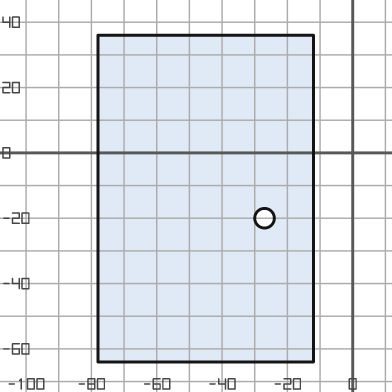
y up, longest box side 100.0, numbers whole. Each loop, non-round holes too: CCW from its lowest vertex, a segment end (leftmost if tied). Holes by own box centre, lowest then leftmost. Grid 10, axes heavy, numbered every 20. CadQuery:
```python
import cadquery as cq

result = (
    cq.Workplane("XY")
    .moveTo(-78.0, -64.0)
    .lineTo(-12.0, -64.0)
    .lineTo(-12.0, 36.0)
    .lineTo(-78.0, 36.0)
    .close()
    .moveTo(-27.0, -20.0)
    .circle(3.0)
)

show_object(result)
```